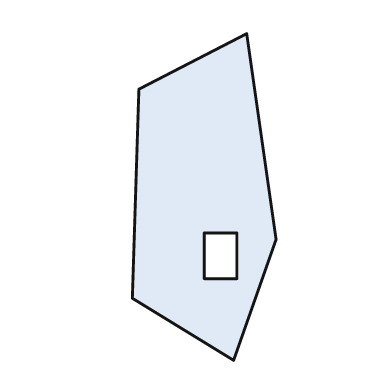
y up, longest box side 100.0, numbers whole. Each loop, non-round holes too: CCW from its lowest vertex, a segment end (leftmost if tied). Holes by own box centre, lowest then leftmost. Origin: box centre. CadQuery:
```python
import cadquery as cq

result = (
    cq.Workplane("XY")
    .moveTo(9.0, -50.0)
    .lineTo(22.0, -13.0)
    .lineTo(13.0, 50.0)
    .lineTo(-20.0, 33.0)
    .lineTo(-22.0, -31.0)
    .close()
    .moveTo(0.0, -25.0)
    .lineTo(10.0, -25.0)
    .lineTo(10.0, -11.0)
    .lineTo(0.0, -11.0)
    .close()
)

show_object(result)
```